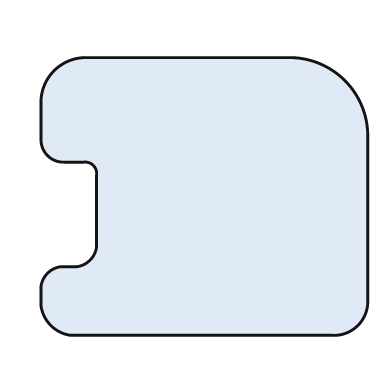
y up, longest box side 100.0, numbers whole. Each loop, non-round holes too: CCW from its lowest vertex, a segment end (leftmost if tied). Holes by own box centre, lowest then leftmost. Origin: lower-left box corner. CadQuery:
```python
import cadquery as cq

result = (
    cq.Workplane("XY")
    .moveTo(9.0, 0.0)
    .lineTo(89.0, 0.0)
    .threePointArc((97.0, 3.0), (100.0, 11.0))
    .lineTo(100.0, 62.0)
    .threePointArc((93.0, 78.0), (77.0, 85.0))
    .lineTo(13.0, 85.0)
    .threePointArc((4.0, 81.0), (0.0, 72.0))
    .lineTo(0.0, 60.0)
    .threePointArc((2.0, 55.0), (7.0, 53.0))
    .lineTo(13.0, 53.0)
    .threePointArc((16.0, 52.0), (17.0, 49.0))
    .lineTo(17.0, 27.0)
    .threePointArc((15.0, 23.0), (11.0, 21.0))
    .lineTo(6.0, 21.0)
    .threePointArc((2.0, 19.0), (0.0, 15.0))
    .lineTo(0.0, 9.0)
    .threePointArc((3.0, 3.0), (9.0, 0.0))
    .close()
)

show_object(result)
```